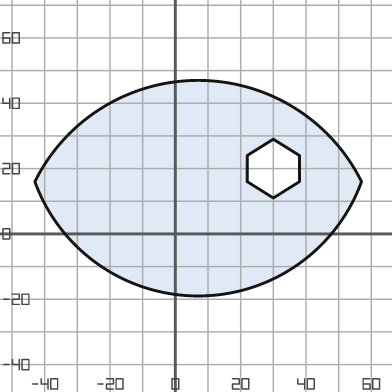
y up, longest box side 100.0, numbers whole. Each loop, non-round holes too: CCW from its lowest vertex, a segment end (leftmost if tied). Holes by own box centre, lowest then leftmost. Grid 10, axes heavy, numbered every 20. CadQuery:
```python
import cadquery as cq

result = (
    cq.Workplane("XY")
    .moveTo(-43.0, 16.0)
    .threePointArc((7.0, -19.0), (57.0, 16.0))
    .threePointArc((7.0, 47.0), (-43.0, 16.0))
    .close()
    .moveTo(30.0, 11.0)
    .lineTo(38.0, 16.0)
    .lineTo(38.0, 24.0)
    .lineTo(30.0, 29.0)
    .lineTo(22.0, 24.0)
    .lineTo(22.0, 16.0)
    .close()
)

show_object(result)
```